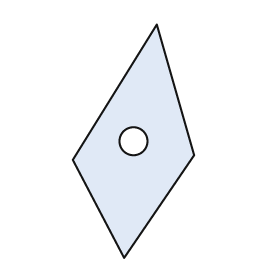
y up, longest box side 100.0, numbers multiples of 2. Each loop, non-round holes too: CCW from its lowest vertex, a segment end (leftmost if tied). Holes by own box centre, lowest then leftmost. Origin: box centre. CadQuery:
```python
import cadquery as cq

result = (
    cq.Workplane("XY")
    .moveTo(-4.0, -50.0)
    .lineTo(26.0, -6.0)
    .lineTo(10.0, 50.0)
    .lineTo(-26.0, -8.0)
    .close()
    .moveTo(0.0, 0.0)
    .circle(6.0)
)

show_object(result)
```